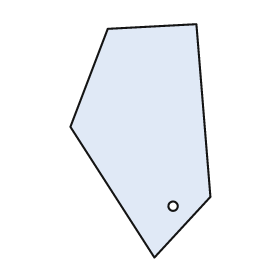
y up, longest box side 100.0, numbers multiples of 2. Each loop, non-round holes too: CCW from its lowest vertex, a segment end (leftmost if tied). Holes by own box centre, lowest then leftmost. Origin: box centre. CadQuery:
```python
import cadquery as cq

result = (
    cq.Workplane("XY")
    .moveTo(6.0, -50.0)
    .lineTo(30.0, -24.0)
    .lineTo(24.0, 50.0)
    .lineTo(-14.0, 48.0)
    .lineTo(-30.0, 6.0)
    .close()
    .moveTo(14.0, -28.0)
    .circle(2.0)
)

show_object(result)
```